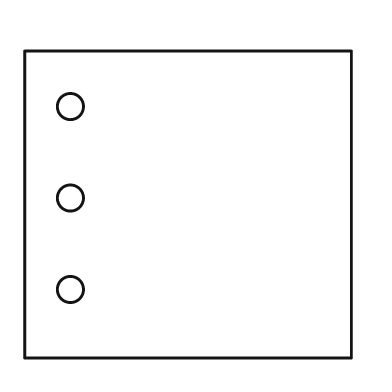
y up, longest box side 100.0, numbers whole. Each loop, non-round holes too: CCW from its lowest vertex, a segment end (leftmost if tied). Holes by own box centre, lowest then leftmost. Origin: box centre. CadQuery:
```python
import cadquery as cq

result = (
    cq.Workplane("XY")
    .moveTo(-50.0, -47.0)
    .lineTo(50.0, -47.0)
    .lineTo(50.0, 47.0)
    .lineTo(-50.0, 47.0)
    .close()
    .moveTo(-36.0, -26.0)
    .circle(4.0)
    .moveTo(-36.0, 2.0)
    .circle(4.0)
    .moveTo(-36.0, 30.0)
    .circle(4.0)
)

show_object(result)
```